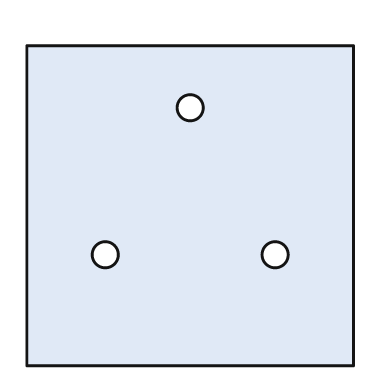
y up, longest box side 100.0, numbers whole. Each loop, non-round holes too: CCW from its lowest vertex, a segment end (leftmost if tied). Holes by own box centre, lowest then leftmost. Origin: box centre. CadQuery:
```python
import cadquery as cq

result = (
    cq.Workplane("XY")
    .moveTo(-50.0, -49.0)
    .lineTo(50.0, -49.0)
    .lineTo(50.0, 49.0)
    .lineTo(-50.0, 49.0)
    .close()
    .moveTo(-26.0, -15.0)
    .circle(4.0)
    .moveTo(26.0, -15.0)
    .circle(4.0)
    .moveTo(0.0, 30.0)
    .circle(4.0)
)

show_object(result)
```